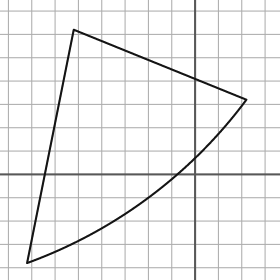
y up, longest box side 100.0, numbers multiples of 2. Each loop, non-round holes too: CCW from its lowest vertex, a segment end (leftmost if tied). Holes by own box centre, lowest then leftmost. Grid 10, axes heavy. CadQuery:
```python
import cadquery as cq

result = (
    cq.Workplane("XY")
    .moveTo(-72.0, -38.0)
    .threePointArc((-20.0, -10.0), (22.0, 32.0))
    .lineTo(-52.0, 62.0)
    .close()
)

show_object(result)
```